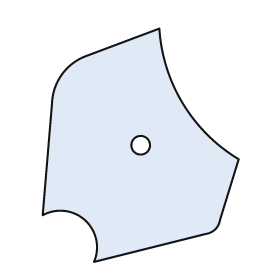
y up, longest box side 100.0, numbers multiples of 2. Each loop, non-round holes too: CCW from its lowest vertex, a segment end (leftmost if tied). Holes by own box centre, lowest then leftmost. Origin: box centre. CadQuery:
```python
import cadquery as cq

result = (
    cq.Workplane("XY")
    .moveTo(-20.0, -50.0)
    .lineTo(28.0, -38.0)
    .threePointArc((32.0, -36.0), (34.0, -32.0))
    .lineTo(42.0, -6.0)
    .threePointArc((18.0, 18.0), (8.0, 50.0))
    .lineTo(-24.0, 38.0)
    .threePointArc((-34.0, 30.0), (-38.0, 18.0))
    .lineTo(-42.0, -30.0)
    .threePointArc((-24.0, -32.0), (-20.0, -50.0))
    .close()
    .moveTo(0.0, 0.0)
    .circle(4.0)
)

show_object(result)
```